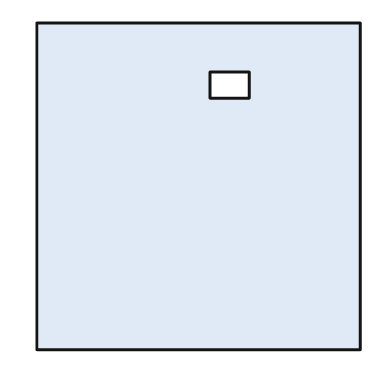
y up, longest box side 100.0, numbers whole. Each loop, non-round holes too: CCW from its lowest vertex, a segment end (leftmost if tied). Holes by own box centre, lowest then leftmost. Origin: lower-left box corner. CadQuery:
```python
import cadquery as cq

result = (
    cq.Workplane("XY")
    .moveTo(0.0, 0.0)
    .lineTo(99.0, 0.0)
    .lineTo(99.0, 100.0)
    .lineTo(0.0, 100.0)
    .close()
    .moveTo(53.0, 77.0)
    .lineTo(65.0, 77.0)
    .lineTo(65.0, 85.0)
    .lineTo(53.0, 85.0)
    .close()
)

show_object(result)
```